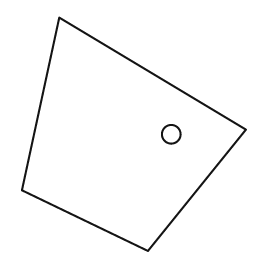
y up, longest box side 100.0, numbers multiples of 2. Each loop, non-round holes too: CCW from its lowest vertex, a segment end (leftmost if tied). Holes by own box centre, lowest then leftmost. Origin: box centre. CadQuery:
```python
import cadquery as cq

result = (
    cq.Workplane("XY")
    .moveTo(6.0, -50.0)
    .lineTo(48.0, 2.0)
    .lineTo(-32.0, 50.0)
    .lineTo(-48.0, -24.0)
    .close()
    .moveTo(16.0, 0.0)
    .circle(4.0)
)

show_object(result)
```